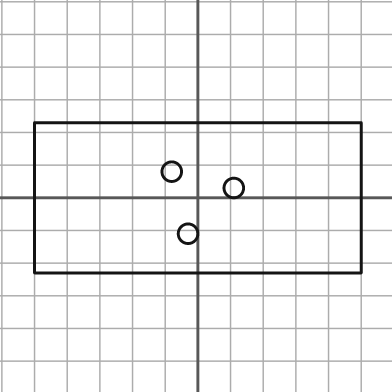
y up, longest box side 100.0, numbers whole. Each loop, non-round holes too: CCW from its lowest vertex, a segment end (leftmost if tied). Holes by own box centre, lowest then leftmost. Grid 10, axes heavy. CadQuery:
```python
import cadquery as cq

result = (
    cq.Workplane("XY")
    .moveTo(-50.0, -23.0)
    .lineTo(50.0, -23.0)
    .lineTo(50.0, 23.0)
    .lineTo(-50.0, 23.0)
    .close()
    .moveTo(-3.0, -11.0)
    .circle(3.0)
    .moveTo(11.0, 3.0)
    .circle(3.0)
    .moveTo(-8.0, 8.0)
    .circle(3.0)
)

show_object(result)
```